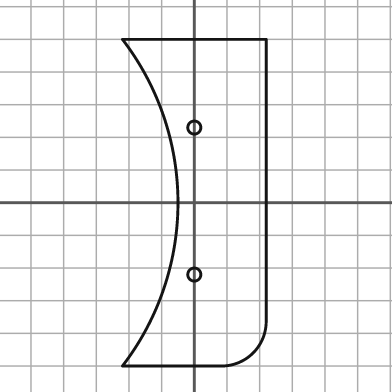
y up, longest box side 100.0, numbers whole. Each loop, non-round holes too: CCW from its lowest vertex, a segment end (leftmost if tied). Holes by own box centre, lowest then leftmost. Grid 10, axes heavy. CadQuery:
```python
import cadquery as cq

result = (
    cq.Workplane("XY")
    .moveTo(-22.0, -50.0)
    .lineTo(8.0, -50.0)
    .threePointArc((18.0, -46.0), (22.0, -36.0))
    .lineTo(22.0, 50.0)
    .lineTo(-22.0, 50.0)
    .threePointArc((-5.0, 0.0), (-22.0, -50.0))
    .close()
    .moveTo(0.0, -22.0)
    .circle(2.0)
    .moveTo(0.0, 23.0)
    .circle(2.0)
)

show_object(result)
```